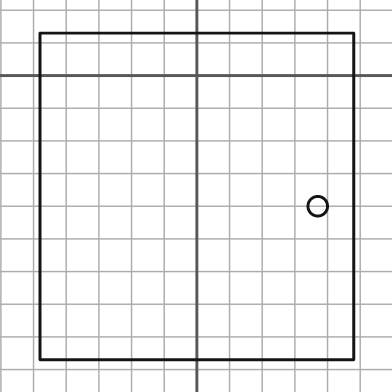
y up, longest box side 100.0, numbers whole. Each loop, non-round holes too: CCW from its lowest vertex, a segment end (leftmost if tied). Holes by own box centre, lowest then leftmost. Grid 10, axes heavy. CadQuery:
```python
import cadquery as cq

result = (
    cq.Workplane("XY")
    .moveTo(-48.0, -87.0)
    .lineTo(48.0, -87.0)
    .lineTo(48.0, 13.0)
    .lineTo(-48.0, 13.0)
    .close()
    .moveTo(37.0, -40.0)
    .circle(3.0)
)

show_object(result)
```